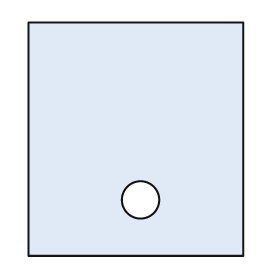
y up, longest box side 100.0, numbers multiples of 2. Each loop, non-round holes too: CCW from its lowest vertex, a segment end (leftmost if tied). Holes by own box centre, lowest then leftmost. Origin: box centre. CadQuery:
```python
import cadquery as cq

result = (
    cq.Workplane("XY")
    .moveTo(-46.0, -50.0)
    .lineTo(46.0, -50.0)
    .lineTo(46.0, 50.0)
    .lineTo(-46.0, 50.0)
    .close()
    .moveTo(2.0, -26.0)
    .circle(8.0)
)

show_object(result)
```